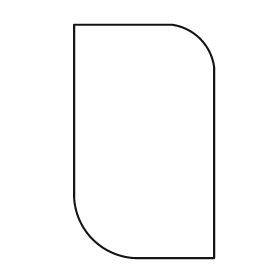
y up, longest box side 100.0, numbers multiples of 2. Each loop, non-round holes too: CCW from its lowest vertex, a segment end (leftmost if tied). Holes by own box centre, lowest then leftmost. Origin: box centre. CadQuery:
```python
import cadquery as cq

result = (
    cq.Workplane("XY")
    .moveTo(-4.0, -50.0)
    .lineTo(30.0, -50.0)
    .lineTo(30.0, 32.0)
    .threePointArc((24.0, 44.0), (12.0, 50.0))
    .lineTo(-30.0, 50.0)
    .lineTo(-30.0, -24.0)
    .threePointArc((-22.0, -42.0), (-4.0, -50.0))
    .close()
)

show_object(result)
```